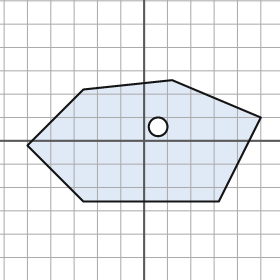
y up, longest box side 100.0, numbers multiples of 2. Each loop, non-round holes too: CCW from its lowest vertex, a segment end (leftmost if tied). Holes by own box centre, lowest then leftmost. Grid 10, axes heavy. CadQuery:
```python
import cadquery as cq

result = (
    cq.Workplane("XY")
    .moveTo(-26.0, -26.0)
    .lineTo(32.0, -26.0)
    .lineTo(50.0, 10.0)
    .lineTo(12.0, 26.0)
    .lineTo(-26.0, 22.0)
    .lineTo(-50.0, -2.0)
    .close()
    .moveTo(6.0, 6.0)
    .circle(4.0)
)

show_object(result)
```